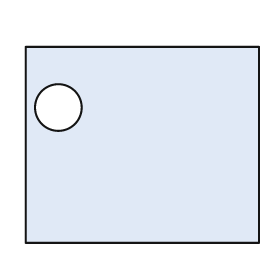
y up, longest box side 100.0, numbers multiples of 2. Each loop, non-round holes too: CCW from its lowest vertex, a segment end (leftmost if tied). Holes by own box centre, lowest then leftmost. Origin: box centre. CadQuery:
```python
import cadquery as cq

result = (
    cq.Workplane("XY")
    .moveTo(-50.0, -42.0)
    .lineTo(50.0, -42.0)
    .lineTo(50.0, 42.0)
    .lineTo(-50.0, 42.0)
    .close()
    .moveTo(-36.0, 16.0)
    .circle(10.0)
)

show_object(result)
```